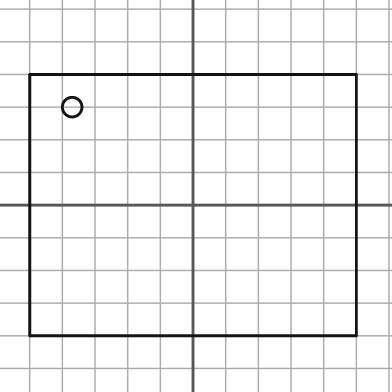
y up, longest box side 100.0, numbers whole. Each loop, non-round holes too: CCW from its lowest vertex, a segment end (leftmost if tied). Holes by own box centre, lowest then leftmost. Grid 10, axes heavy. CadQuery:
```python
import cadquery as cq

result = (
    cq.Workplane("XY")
    .moveTo(-50.0, -40.0)
    .lineTo(50.0, -40.0)
    .lineTo(50.0, 40.0)
    .lineTo(-50.0, 40.0)
    .close()
    .moveTo(-37.0, 30.0)
    .circle(3.0)
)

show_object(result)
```